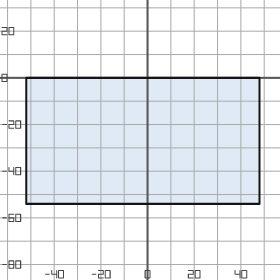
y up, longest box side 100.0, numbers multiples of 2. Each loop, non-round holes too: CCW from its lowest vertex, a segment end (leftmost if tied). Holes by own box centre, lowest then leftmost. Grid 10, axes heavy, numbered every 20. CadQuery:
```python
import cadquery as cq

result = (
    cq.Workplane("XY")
    .moveTo(-52.0, -54.0)
    .lineTo(48.0, -54.0)
    .lineTo(48.0, 0.0)
    .lineTo(-52.0, 0.0)
    .close()
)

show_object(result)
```